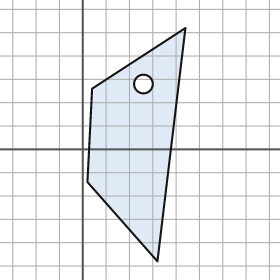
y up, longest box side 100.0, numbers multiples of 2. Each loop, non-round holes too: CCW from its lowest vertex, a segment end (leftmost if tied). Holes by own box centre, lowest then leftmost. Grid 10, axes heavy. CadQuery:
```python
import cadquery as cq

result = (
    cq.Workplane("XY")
    .moveTo(32.0, -48.0)
    .lineTo(44.0, 52.0)
    .lineTo(4.0, 26.0)
    .lineTo(2.0, -14.0)
    .close()
    .moveTo(26.0, 28.0)
    .circle(4.0)
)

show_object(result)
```